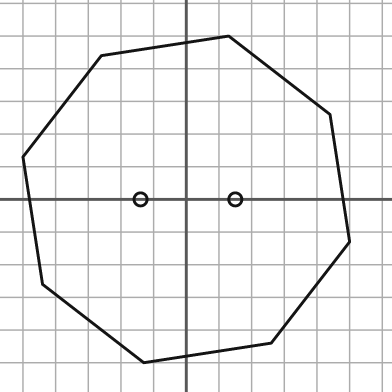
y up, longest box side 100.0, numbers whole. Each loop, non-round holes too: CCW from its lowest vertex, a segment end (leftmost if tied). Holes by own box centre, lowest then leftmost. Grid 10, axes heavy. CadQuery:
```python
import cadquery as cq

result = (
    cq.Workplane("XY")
    .moveTo(-13.0, -50.0)
    .lineTo(26.0, -44.0)
    .lineTo(50.0, -13.0)
    .lineTo(44.0, 26.0)
    .lineTo(13.0, 50.0)
    .lineTo(-26.0, 44.0)
    .lineTo(-50.0, 13.0)
    .lineTo(-44.0, -26.0)
    .close()
    .moveTo(-14.0, 0.0)
    .circle(2.0)
    .moveTo(15.0, 0.0)
    .circle(2.0)
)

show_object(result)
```